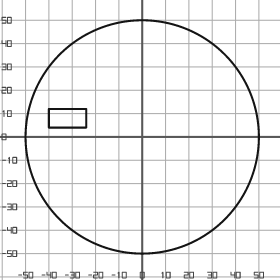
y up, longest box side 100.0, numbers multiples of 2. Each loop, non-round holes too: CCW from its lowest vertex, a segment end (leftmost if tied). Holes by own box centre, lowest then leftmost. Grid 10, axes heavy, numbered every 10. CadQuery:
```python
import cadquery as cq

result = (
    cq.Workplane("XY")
    .moveTo(0.0, 0.0)
    .circle(50.0)
    .moveTo(-40.0, 4.0)
    .lineTo(-24.0, 4.0)
    .lineTo(-24.0, 12.0)
    .lineTo(-40.0, 12.0)
    .close()
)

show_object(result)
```